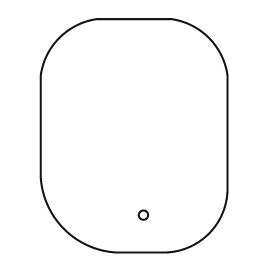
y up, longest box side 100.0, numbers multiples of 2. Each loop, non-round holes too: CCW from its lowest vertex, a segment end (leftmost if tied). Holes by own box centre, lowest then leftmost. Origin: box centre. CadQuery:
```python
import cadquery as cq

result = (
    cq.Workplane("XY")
    .moveTo(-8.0, -50.0)
    .lineTo(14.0, -50.0)
    .threePointArc((32.0, -42.0), (40.0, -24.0))
    .lineTo(40.0, 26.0)
    .threePointArc((32.0, 42.0), (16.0, 50.0))
    .lineTo(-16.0, 50.0)
    .threePointArc((-32.0, 42.0), (-40.0, 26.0))
    .lineTo(-40.0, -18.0)
    .threePointArc((-30.0, -40.0), (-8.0, -50.0))
    .close()
    .moveTo(4.0, -34.0)
    .circle(2.0)
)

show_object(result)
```